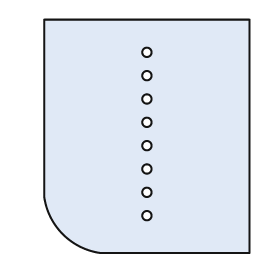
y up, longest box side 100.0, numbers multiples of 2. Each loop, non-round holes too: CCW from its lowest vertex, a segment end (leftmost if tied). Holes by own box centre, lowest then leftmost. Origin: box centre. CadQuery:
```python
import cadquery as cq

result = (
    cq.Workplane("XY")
    .moveTo(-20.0, -50.0)
    .lineTo(44.0, -50.0)
    .lineTo(44.0, 50.0)
    .lineTo(-44.0, 50.0)
    .lineTo(-44.0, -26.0)
    .threePointArc((-36.0, -42.0), (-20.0, -50.0))
    .close()
    .moveTo(0.0, -34.0)
    .circle(2.0)
    .moveTo(0.0, -24.0)
    .circle(2.0)
    .moveTo(0.0, -14.0)
    .circle(2.0)
    .moveTo(0.0, -4.0)
    .circle(2.0)
    .moveTo(0.0, 6.0)
    .circle(2.0)
    .moveTo(0.0, 16.0)
    .circle(2.0)
    .moveTo(0.0, 26.0)
    .circle(2.0)
    .moveTo(0.0, 36.0)
    .circle(2.0)
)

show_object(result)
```